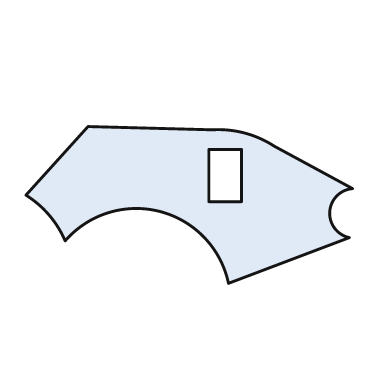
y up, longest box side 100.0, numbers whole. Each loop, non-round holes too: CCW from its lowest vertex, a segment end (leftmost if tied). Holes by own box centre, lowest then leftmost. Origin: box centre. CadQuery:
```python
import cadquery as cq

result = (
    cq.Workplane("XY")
    .moveTo(12.0, -24.0)
    .lineTo(49.0, -10.0)
    .threePointArc((43.0, -2.0), (50.0, 5.0))
    .lineTo(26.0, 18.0)
    .threePointArc((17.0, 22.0), (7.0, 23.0))
    .lineTo(-31.0, 24.0)
    .lineTo(-50.0, 3.0)
    .threePointArc((-43.0, -3.0), (-38.0, -11.0))
    .threePointArc((-9.0, -2.0), (12.0, -24.0))
    .close()
    .moveTo(6.0, 1.0)
    .lineTo(16.0, 1.0)
    .lineTo(16.0, 17.0)
    .lineTo(6.0, 17.0)
    .close()
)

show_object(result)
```